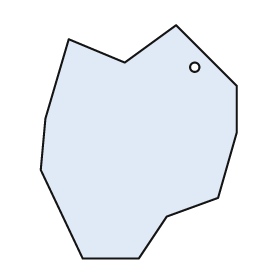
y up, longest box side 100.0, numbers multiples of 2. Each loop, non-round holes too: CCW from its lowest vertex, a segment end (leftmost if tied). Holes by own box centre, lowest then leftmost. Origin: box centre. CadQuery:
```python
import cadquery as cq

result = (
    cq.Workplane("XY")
    .moveTo(-24.0, -50.0)
    .lineTo(0.0, -50.0)
    .lineTo(12.0, -32.0)
    .lineTo(34.0, -24.0)
    .lineTo(42.0, 4.0)
    .lineTo(42.0, 24.0)
    .lineTo(16.0, 50.0)
    .lineTo(-6.0, 34.0)
    .lineTo(-30.0, 44.0)
    .lineTo(-40.0, 10.0)
    .lineTo(-42.0, -12.0)
    .close()
    .moveTo(24.0, 32.0)
    .circle(2.0)
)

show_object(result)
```